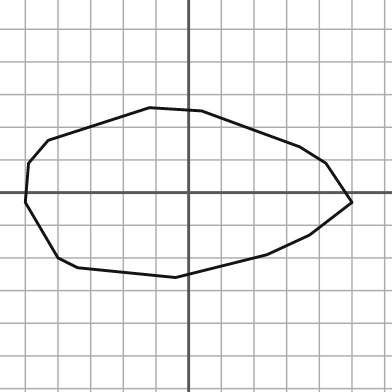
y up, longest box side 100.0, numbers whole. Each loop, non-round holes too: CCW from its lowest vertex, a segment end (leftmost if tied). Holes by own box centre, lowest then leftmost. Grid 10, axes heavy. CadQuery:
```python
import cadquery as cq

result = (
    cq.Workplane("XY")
    .moveTo(-4.0, -26.0)
    .lineTo(24.0, -19.0)
    .lineTo(37.0, -13.0)
    .lineTo(50.0, -3.0)
    .lineTo(42.0, 9.0)
    .lineTo(34.0, 14.0)
    .lineTo(4.0, 25.0)
    .lineTo(-12.0, 26.0)
    .lineTo(-43.0, 16.0)
    .lineTo(-49.0, 9.0)
    .lineTo(-50.0, -3.0)
    .lineTo(-40.0, -20.0)
    .lineTo(-34.0, -23.0)
    .close()
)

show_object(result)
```